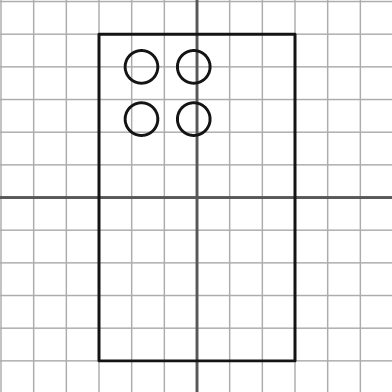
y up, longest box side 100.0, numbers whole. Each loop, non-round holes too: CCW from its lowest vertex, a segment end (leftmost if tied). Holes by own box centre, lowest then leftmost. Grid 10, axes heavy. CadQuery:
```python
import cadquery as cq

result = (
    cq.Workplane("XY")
    .moveTo(-30.0, -50.0)
    .lineTo(30.0, -50.0)
    .lineTo(30.0, 50.0)
    .lineTo(-30.0, 50.0)
    .close()
    .moveTo(-17.0, 24.0)
    .circle(5.0)
    .moveTo(-1.0, 24.0)
    .circle(5.0)
    .moveTo(-17.0, 40.0)
    .circle(5.0)
    .moveTo(-1.0, 40.0)
    .circle(5.0)
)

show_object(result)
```